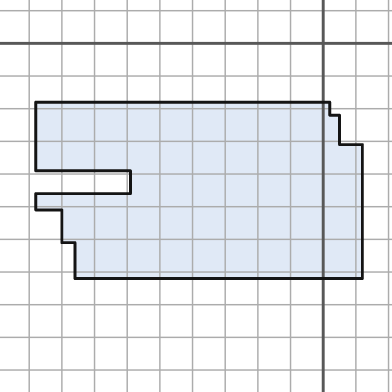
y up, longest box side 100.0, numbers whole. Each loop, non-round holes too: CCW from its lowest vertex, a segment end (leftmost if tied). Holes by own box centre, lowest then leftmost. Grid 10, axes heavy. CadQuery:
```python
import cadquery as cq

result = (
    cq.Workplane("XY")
    .moveTo(-76.0, -72.0)
    .lineTo(12.0, -72.0)
    .lineTo(12.0, -31.0)
    .lineTo(5.0, -31.0)
    .lineTo(5.0, -22.0)
    .lineTo(2.0, -22.0)
    .lineTo(2.0, -18.0)
    .lineTo(-88.0, -18.0)
    .lineTo(-88.0, -39.0)
    .lineTo(-59.0, -39.0)
    .lineTo(-59.0, -46.0)
    .lineTo(-88.0, -46.0)
    .lineTo(-88.0, -51.0)
    .lineTo(-80.0, -51.0)
    .lineTo(-80.0, -61.0)
    .lineTo(-76.0, -61.0)
    .close()
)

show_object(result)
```